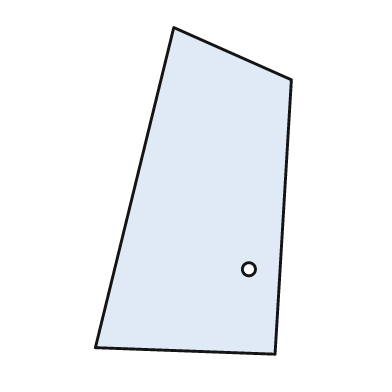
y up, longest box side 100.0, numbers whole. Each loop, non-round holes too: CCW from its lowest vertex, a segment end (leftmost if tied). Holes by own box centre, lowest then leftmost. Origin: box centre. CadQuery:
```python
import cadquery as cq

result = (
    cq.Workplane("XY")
    .moveTo(25.0, -50.0)
    .lineTo(30.0, 34.0)
    .lineTo(-6.0, 50.0)
    .lineTo(-30.0, -48.0)
    .close()
    .moveTo(17.0, -24.0)
    .circle(2.0)
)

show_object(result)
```